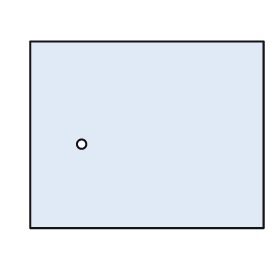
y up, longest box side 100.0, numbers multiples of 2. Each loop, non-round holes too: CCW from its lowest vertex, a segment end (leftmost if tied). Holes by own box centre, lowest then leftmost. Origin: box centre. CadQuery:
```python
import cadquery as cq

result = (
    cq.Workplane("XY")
    .moveTo(-50.0, -40.0)
    .lineTo(50.0, -40.0)
    .lineTo(50.0, 40.0)
    .lineTo(-50.0, 40.0)
    .close()
    .moveTo(-28.0, -4.0)
    .circle(2.0)
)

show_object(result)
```